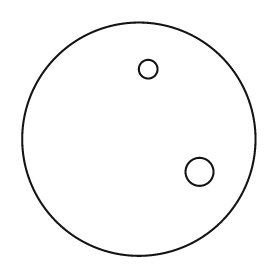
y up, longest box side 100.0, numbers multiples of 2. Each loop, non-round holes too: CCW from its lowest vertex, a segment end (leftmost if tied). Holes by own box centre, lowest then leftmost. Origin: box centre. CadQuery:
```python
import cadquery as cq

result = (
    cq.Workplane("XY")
    .moveTo(0.0, 0.0)
    .circle(50.0)
    .moveTo(26.0, -14.0)
    .circle(6.0)
    .moveTo(4.0, 30.0)
    .circle(4.0)
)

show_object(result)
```